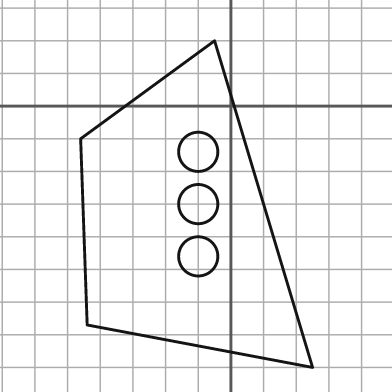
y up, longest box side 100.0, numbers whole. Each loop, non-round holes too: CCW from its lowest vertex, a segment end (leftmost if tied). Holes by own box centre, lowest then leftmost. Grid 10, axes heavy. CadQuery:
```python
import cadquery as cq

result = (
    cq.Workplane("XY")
    .moveTo(25.0, -80.0)
    .lineTo(-5.0, 20.0)
    .lineTo(-46.0, -10.0)
    .lineTo(-44.0, -67.0)
    .close()
    .moveTo(-10.0, -46.0)
    .circle(6.0)
    .moveTo(-10.0, -30.0)
    .circle(6.0)
    .moveTo(-10.0, -14.0)
    .circle(6.0)
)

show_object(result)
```